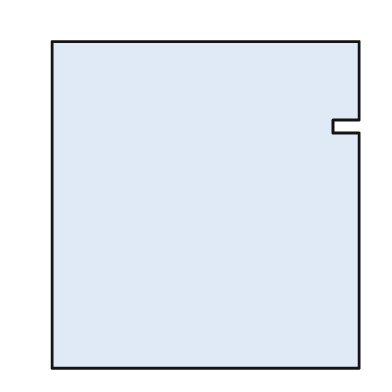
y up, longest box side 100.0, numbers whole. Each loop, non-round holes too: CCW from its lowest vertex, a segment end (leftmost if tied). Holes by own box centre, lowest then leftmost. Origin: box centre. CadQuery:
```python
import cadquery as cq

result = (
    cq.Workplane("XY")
    .moveTo(-47.0, -50.0)
    .lineTo(47.0, -50.0)
    .lineTo(47.0, 22.0)
    .lineTo(39.0, 22.0)
    .lineTo(39.0, 26.0)
    .lineTo(47.0, 26.0)
    .lineTo(47.0, 50.0)
    .lineTo(-47.0, 50.0)
    .close()
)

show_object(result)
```